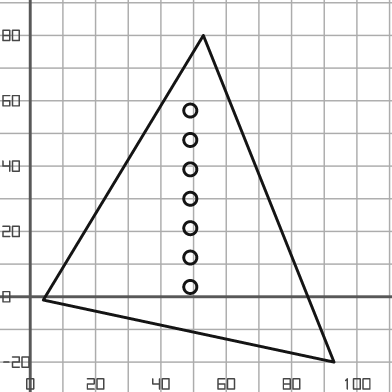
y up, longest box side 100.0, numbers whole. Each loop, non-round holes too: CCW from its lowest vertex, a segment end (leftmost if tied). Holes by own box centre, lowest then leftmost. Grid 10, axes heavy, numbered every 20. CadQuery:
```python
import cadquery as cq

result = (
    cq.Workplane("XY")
    .moveTo(93.0, -20.0)
    .lineTo(53.0, 80.0)
    .lineTo(4.0, -1.0)
    .close()
    .moveTo(49.0, 3.0)
    .circle(2.0)
    .moveTo(49.0, 12.0)
    .circle(2.0)
    .moveTo(49.0, 21.0)
    .circle(2.0)
    .moveTo(49.0, 30.0)
    .circle(2.0)
    .moveTo(49.0, 39.0)
    .circle(2.0)
    .moveTo(49.0, 48.0)
    .circle(2.0)
    .moveTo(49.0, 57.0)
    .circle(2.0)
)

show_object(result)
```